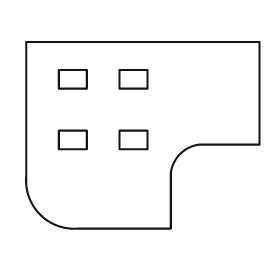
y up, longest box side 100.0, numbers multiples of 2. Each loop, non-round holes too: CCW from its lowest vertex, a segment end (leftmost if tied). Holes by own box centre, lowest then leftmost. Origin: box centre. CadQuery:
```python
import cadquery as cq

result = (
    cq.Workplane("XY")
    .moveTo(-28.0, -40.0)
    .lineTo(12.0, -40.0)
    .lineTo(12.0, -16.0)
    .threePointArc((16.0, -8.0), (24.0, -4.0))
    .lineTo(50.0, -4.0)
    .lineTo(50.0, 40.0)
    .lineTo(-50.0, 40.0)
    .lineTo(-50.0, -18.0)
    .threePointArc((-44.0, -34.0), (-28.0, -40.0))
    .close()
    .moveTo(-36.0, -6.0)
    .lineTo(-24.0, -6.0)
    .lineTo(-24.0, 2.0)
    .lineTo(-36.0, 2.0)
    .close()
    .moveTo(-10.0, -6.0)
    .lineTo(2.0, -6.0)
    .lineTo(2.0, 2.0)
    .lineTo(-10.0, 2.0)
    .close()
    .moveTo(-36.0, 20.0)
    .lineTo(-24.0, 20.0)
    .lineTo(-24.0, 28.0)
    .lineTo(-36.0, 28.0)
    .close()
    .moveTo(-10.0, 20.0)
    .lineTo(2.0, 20.0)
    .lineTo(2.0, 28.0)
    .lineTo(-10.0, 28.0)
    .close()
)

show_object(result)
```